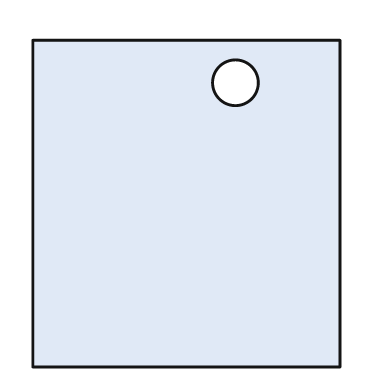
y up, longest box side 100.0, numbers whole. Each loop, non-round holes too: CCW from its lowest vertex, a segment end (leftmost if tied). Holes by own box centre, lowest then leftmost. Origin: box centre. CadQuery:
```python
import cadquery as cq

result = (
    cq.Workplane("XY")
    .moveTo(-47.0, -50.0)
    .lineTo(47.0, -50.0)
    .lineTo(47.0, 50.0)
    .lineTo(-47.0, 50.0)
    .close()
    .moveTo(15.0, 37.0)
    .circle(7.0)
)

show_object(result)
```